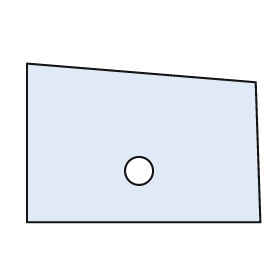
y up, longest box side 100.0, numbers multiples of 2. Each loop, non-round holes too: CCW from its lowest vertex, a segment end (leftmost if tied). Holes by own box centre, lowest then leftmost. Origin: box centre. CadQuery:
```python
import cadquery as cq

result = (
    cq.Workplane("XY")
    .moveTo(-50.0, -34.0)
    .lineTo(50.0, -34.0)
    .lineTo(48.0, 26.0)
    .lineTo(-50.0, 34.0)
    .close()
    .moveTo(-2.0, -12.0)
    .circle(6.0)
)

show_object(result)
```